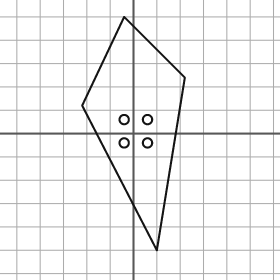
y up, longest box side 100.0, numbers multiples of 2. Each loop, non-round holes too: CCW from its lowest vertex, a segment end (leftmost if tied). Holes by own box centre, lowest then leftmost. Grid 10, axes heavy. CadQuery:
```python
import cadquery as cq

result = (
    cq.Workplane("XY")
    .moveTo(10.0, -50.0)
    .lineTo(22.0, 24.0)
    .lineTo(-4.0, 50.0)
    .lineTo(-22.0, 12.0)
    .close()
    .moveTo(-4.0, -4.0)
    .circle(2.0)
    .moveTo(6.0, -4.0)
    .circle(2.0)
    .moveTo(-4.0, 6.0)
    .circle(2.0)
    .moveTo(6.0, 6.0)
    .circle(2.0)
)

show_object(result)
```